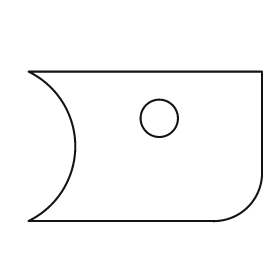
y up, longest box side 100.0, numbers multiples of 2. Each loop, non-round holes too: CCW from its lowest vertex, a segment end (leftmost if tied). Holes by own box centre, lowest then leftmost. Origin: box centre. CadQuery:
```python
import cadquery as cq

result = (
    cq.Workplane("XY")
    .moveTo(-50.0, -32.0)
    .lineTo(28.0, -32.0)
    .threePointArc((44.0, -26.0), (50.0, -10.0))
    .lineTo(50.0, 32.0)
    .lineTo(-50.0, 32.0)
    .threePointArc((-30.0, 0.0), (-50.0, -32.0))
    .close()
    .moveTo(6.0, 12.0)
    .circle(8.0)
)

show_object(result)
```